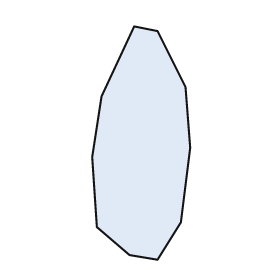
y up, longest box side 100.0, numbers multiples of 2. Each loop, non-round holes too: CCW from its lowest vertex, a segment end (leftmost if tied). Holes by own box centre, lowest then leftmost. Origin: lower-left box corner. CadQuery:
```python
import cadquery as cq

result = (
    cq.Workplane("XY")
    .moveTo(28.0, 0.0)
    .lineTo(38.0, 16.0)
    .lineTo(42.0, 48.0)
    .lineTo(40.0, 74.0)
    .lineTo(28.0, 98.0)
    .lineTo(18.0, 100.0)
    .lineTo(4.0, 70.0)
    .lineTo(0.0, 44.0)
    .lineTo(2.0, 14.0)
    .lineTo(16.0, 2.0)
    .close()
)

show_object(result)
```